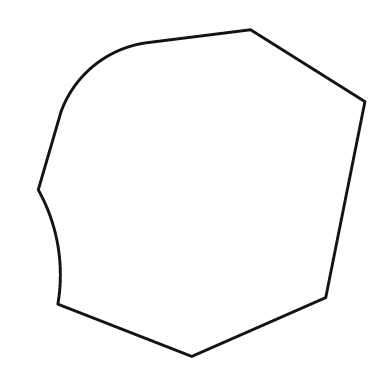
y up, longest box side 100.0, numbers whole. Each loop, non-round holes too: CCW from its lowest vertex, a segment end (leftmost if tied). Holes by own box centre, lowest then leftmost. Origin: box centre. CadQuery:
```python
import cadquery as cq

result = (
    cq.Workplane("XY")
    .moveTo(-3.0, -50.0)
    .lineTo(38.0, -32.0)
    .lineTo(50.0, 28.0)
    .lineTo(15.0, 50.0)
    .lineTo(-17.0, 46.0)
    .threePointArc((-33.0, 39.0), (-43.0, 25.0))
    .lineTo(-50.0, 1.0)
    .threePointArc((-44.0, -16.0), (-44.0, -34.0))
    .close()
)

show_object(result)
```